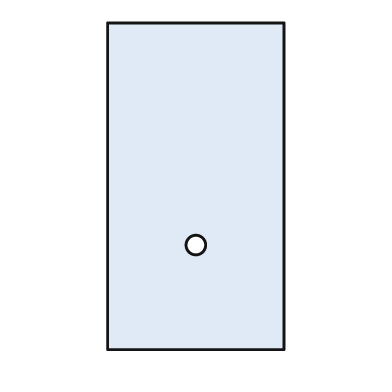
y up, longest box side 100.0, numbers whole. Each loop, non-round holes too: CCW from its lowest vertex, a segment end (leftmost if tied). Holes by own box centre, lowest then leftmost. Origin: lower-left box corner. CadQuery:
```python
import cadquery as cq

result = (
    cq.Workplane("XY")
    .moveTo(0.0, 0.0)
    .lineTo(54.0, 0.0)
    .lineTo(54.0, 100.0)
    .lineTo(0.0, 100.0)
    .close()
    .moveTo(27.0, 32.0)
    .circle(3.0)
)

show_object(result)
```